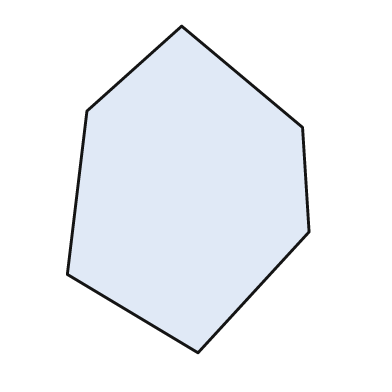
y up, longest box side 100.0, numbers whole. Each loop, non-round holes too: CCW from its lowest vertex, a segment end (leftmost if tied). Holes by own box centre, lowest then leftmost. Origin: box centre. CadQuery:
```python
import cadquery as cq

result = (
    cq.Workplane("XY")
    .moveTo(3.0, -50.0)
    .lineTo(37.0, -13.0)
    .lineTo(35.0, 19.0)
    .lineTo(-2.0, 50.0)
    .lineTo(-31.0, 24.0)
    .lineTo(-37.0, -26.0)
    .close()
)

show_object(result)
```